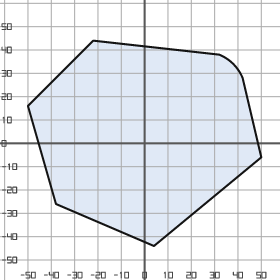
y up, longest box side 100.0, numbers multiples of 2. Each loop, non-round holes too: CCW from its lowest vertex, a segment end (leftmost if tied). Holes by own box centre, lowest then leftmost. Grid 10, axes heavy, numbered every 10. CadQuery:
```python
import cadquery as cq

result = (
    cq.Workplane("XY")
    .moveTo(4.0, -44.0)
    .lineTo(50.0, -6.0)
    .lineTo(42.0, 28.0)
    .threePointArc((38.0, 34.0), (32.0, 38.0))
    .lineTo(-22.0, 44.0)
    .lineTo(-50.0, 16.0)
    .lineTo(-38.0, -26.0)
    .close()
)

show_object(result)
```